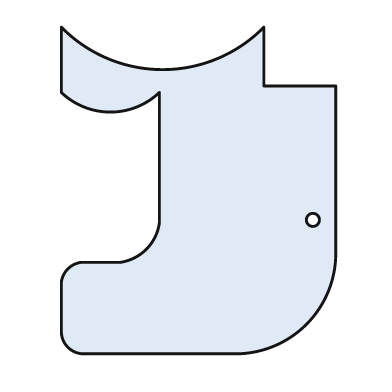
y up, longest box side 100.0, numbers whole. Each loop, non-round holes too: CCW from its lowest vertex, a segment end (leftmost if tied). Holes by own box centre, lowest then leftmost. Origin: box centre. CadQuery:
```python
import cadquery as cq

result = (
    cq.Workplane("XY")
    .moveTo(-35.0, -50.0)
    .lineTo(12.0, -50.0)
    .threePointArc((33.0, -41.0), (42.0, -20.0))
    .lineTo(42.0, 32.0)
    .lineTo(20.0, 32.0)
    .lineTo(20.0, 50.0)
    .threePointArc((-11.0, 37.0), (-42.0, 50.0))
    .lineTo(-42.0, 30.0)
    .threePointArc((-27.0, 24.0), (-12.0, 30.0))
    .lineTo(-12.0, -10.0)
    .threePointArc((-16.0, -18.0), (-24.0, -22.0))
    .lineTo(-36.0, -22.0)
    .threePointArc((-40.0, -24.0), (-42.0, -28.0))
    .lineTo(-42.0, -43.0)
    .threePointArc((-40.0, -48.0), (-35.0, -50.0))
    .close()
    .moveTo(35.0, -9.0)
    .circle(2.0)
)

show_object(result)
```